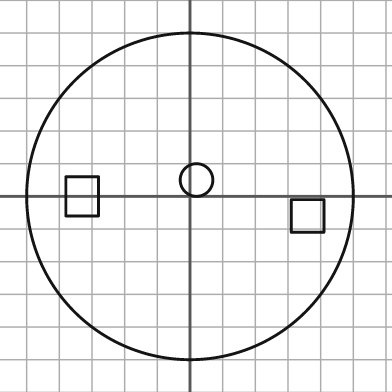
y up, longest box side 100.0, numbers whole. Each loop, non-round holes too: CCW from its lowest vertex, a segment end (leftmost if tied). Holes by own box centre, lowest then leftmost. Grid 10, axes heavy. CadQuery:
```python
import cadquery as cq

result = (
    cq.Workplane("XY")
    .moveTo(0.0, 0.0)
    .circle(50.0)
    .moveTo(31.0, -11.0)
    .lineTo(41.0, -11.0)
    .lineTo(41.0, -1.0)
    .lineTo(31.0, -1.0)
    .close()
    .moveTo(-38.0, -6.0)
    .lineTo(-28.0, -6.0)
    .lineTo(-28.0, 6.0)
    .lineTo(-38.0, 6.0)
    .close()
    .moveTo(2.0, 5.0)
    .circle(5.0)
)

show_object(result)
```